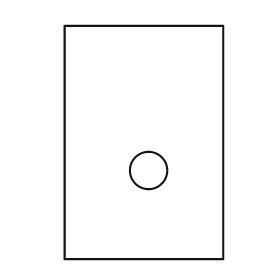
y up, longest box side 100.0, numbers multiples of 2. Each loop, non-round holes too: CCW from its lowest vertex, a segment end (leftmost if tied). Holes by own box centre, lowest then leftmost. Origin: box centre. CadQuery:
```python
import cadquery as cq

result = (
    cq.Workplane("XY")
    .moveTo(-34.0, -50.0)
    .lineTo(34.0, -50.0)
    .lineTo(34.0, 50.0)
    .lineTo(-34.0, 50.0)
    .close()
    .moveTo(2.0, -12.0)
    .circle(8.0)
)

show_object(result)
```